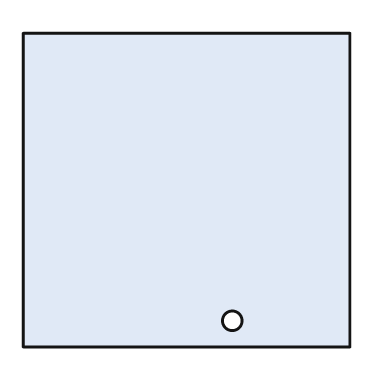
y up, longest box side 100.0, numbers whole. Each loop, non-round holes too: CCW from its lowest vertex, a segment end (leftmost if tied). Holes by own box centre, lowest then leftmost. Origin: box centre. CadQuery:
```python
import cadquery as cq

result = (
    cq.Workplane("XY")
    .moveTo(-50.0, -48.0)
    .lineTo(50.0, -48.0)
    .lineTo(50.0, 48.0)
    .lineTo(-50.0, 48.0)
    .close()
    .moveTo(14.0, -40.0)
    .circle(3.0)
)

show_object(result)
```